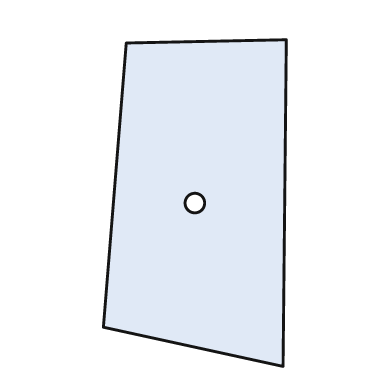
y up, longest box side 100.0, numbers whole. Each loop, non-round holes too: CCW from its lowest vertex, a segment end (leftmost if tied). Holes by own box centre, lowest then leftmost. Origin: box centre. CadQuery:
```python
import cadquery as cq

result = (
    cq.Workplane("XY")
    .moveTo(27.0, -50.0)
    .lineTo(28.0, 50.0)
    .lineTo(-21.0, 49.0)
    .lineTo(-28.0, -38.0)
    .close()
    .moveTo(0.0, 0.0)
    .circle(3.0)
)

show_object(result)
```